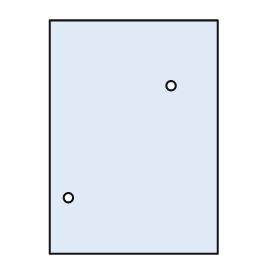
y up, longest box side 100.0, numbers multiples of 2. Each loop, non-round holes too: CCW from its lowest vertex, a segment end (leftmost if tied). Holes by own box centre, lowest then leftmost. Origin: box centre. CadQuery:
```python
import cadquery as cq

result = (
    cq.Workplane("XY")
    .moveTo(-36.0, -50.0)
    .lineTo(36.0, -50.0)
    .lineTo(36.0, 50.0)
    .lineTo(-36.0, 50.0)
    .close()
    .moveTo(-28.0, -26.0)
    .circle(2.0)
    .moveTo(16.0, 22.0)
    .circle(2.0)
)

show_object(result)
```